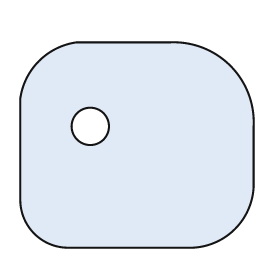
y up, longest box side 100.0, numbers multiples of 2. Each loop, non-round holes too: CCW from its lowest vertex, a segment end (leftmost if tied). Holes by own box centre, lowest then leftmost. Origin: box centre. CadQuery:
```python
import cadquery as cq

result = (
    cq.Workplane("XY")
    .moveTo(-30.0, -44.0)
    .lineTo(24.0, -44.0)
    .threePointArc((42.0, -36.0), (50.0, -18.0))
    .lineTo(50.0, 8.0)
    .threePointArc((40.0, 34.0), (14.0, 44.0))
    .lineTo(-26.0, 44.0)
    .threePointArc((-42.0, 36.0), (-50.0, 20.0))
    .lineTo(-50.0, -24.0)
    .threePointArc((-44.0, -38.0), (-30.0, -44.0))
    .close()
    .moveTo(-20.0, 8.0)
    .circle(8.0)
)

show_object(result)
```